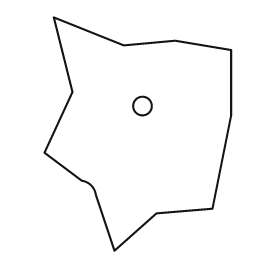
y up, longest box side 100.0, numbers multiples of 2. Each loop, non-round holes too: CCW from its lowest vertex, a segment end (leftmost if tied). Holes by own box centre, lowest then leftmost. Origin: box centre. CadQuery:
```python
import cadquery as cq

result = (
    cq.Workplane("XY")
    .moveTo(-10.0, -50.0)
    .lineTo(8.0, -34.0)
    .lineTo(32.0, -32.0)
    .lineTo(40.0, 8.0)
    .lineTo(40.0, 36.0)
    .lineTo(16.0, 40.0)
    .lineTo(-6.0, 38.0)
    .lineTo(-36.0, 50.0)
    .lineTo(-28.0, 18.0)
    .lineTo(-40.0, -8.0)
    .lineTo(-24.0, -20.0)
    .threePointArc((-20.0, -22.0), (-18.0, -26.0))
    .close()
    .moveTo(2.0, 12.0)
    .circle(4.0)
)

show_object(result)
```